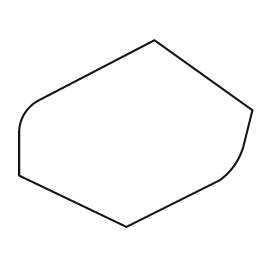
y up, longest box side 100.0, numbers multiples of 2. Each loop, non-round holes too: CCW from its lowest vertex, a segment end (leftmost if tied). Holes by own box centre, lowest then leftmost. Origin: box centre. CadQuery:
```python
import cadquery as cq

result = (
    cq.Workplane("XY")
    .moveTo(-4.0, -40.0)
    .lineTo(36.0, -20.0)
    .threePointArc((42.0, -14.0), (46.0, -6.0))
    .lineTo(50.0, 10.0)
    .lineTo(8.0, 40.0)
    .lineTo(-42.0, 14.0)
    .threePointArc((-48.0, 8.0), (-50.0, 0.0))
    .lineTo(-50.0, -18.0)
    .close()
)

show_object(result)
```